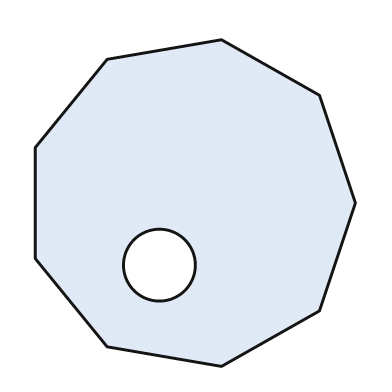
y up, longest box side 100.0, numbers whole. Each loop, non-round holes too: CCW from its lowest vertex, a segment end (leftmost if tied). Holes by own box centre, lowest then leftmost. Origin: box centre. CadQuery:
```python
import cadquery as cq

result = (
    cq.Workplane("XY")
    .moveTo(8.0, -50.0)
    .lineTo(38.0, -33.0)
    .lineTo(49.0, 0.0)
    .lineTo(38.0, 33.0)
    .lineTo(8.0, 50.0)
    .lineTo(-27.0, 44.0)
    .lineTo(-49.0, 17.0)
    .lineTo(-49.0, -17.0)
    .lineTo(-27.0, -44.0)
    .close()
    .moveTo(-11.0, -19.0)
    .circle(11.0)
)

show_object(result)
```